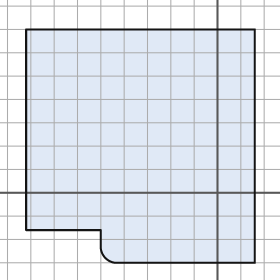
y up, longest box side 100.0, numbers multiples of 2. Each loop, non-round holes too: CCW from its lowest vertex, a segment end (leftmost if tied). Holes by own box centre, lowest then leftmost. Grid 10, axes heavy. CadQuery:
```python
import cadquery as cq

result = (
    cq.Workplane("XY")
    .moveTo(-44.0, -30.0)
    .lineTo(16.0, -30.0)
    .lineTo(16.0, 70.0)
    .lineTo(-82.0, 70.0)
    .lineTo(-82.0, -16.0)
    .lineTo(-50.0, -16.0)
    .lineTo(-50.0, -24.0)
    .threePointArc((-48.0, -28.0), (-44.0, -30.0))
    .close()
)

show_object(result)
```